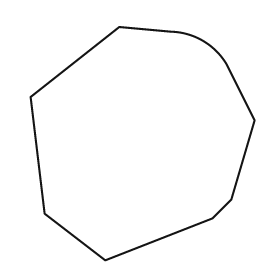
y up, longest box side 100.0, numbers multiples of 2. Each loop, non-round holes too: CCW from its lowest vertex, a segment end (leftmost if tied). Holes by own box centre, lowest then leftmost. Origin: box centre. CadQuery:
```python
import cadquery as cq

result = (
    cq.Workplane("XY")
    .moveTo(-16.0, -50.0)
    .lineTo(30.0, -32.0)
    .lineTo(38.0, -24.0)
    .lineTo(48.0, 10.0)
    .lineTo(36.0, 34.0)
    .threePointArc((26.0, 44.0), (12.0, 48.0))
    .lineTo(-10.0, 50.0)
    .lineTo(-48.0, 20.0)
    .lineTo(-42.0, -30.0)
    .close()
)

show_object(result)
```